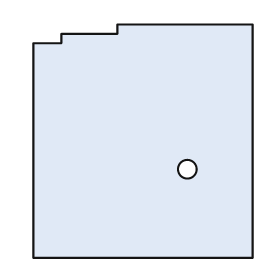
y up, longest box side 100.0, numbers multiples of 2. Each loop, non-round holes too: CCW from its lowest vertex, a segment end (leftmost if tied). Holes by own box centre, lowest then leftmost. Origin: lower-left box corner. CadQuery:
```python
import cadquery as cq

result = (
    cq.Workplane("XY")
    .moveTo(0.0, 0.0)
    .lineTo(94.0, 0.0)
    .lineTo(94.0, 100.0)
    .lineTo(36.0, 100.0)
    .lineTo(36.0, 96.0)
    .lineTo(12.0, 96.0)
    .lineTo(12.0, 92.0)
    .lineTo(0.0, 92.0)
    .close()
    .moveTo(66.0, 38.0)
    .circle(4.0)
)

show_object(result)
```